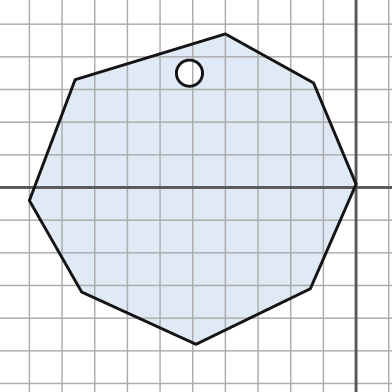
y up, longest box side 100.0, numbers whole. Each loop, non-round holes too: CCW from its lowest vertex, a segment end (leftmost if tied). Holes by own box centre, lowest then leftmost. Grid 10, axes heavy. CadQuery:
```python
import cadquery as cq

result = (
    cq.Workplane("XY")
    .moveTo(-49.0, -48.0)
    .lineTo(-14.0, -31.0)
    .lineTo(0.0, 1.0)
    .lineTo(-13.0, 32.0)
    .lineTo(-40.0, 47.0)
    .lineTo(-86.0, 33.0)
    .lineTo(-100.0, -4.0)
    .lineTo(-84.0, -32.0)
    .close()
    .moveTo(-51.0, 35.0)
    .circle(4.0)
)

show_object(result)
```